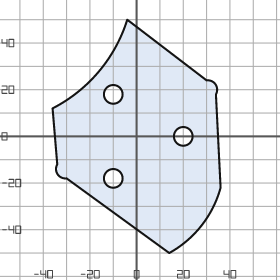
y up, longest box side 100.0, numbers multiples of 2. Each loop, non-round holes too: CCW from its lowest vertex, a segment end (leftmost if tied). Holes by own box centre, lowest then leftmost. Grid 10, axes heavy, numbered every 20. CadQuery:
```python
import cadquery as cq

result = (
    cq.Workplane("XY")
    .moveTo(14.0, -50.0)
    .threePointArc((28.0, -38.0), (36.0, -22.0))
    .lineTo(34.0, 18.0)
    .threePointArc((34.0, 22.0), (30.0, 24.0))
    .lineTo(-4.0, 50.0)
    .threePointArc((-16.0, 28.0), (-36.0, 12.0))
    .lineTo(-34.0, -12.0)
    .threePointArc((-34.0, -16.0), (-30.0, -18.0))
    .close()
    .moveTo(-10.0, -18.0)
    .circle(4.0)
    .moveTo(20.0, 0.0)
    .circle(4.0)
    .moveTo(-10.0, 18.0)
    .circle(4.0)
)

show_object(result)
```